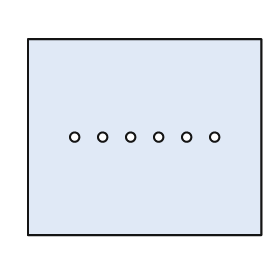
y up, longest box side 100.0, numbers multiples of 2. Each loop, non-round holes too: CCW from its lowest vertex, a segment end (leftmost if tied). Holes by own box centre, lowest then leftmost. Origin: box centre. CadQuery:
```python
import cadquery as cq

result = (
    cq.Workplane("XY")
    .moveTo(-50.0, -42.0)
    .lineTo(50.0, -42.0)
    .lineTo(50.0, 42.0)
    .lineTo(-50.0, 42.0)
    .close()
    .moveTo(-30.0, 0.0)
    .circle(2.0)
    .moveTo(-18.0, 0.0)
    .circle(2.0)
    .moveTo(-6.0, 0.0)
    .circle(2.0)
    .moveTo(6.0, 0.0)
    .circle(2.0)
    .moveTo(18.0, 0.0)
    .circle(2.0)
    .moveTo(30.0, 0.0)
    .circle(2.0)
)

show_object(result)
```